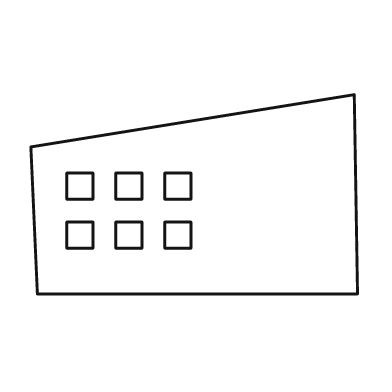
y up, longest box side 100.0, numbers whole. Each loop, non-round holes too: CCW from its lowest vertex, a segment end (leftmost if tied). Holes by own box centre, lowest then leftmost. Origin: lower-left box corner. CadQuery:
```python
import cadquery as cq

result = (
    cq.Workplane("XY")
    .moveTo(2.0, 0.0)
    .lineTo(100.0, 0.0)
    .lineTo(99.0, 61.0)
    .lineTo(0.0, 45.0)
    .close()
    .moveTo(11.0, 14.0)
    .lineTo(19.0, 14.0)
    .lineTo(19.0, 22.0)
    .lineTo(11.0, 22.0)
    .close()
    .moveTo(26.0, 14.0)
    .lineTo(34.0, 14.0)
    .lineTo(34.0, 22.0)
    .lineTo(26.0, 22.0)
    .close()
    .moveTo(41.0, 14.0)
    .lineTo(49.0, 14.0)
    .lineTo(49.0, 22.0)
    .lineTo(41.0, 22.0)
    .close()
    .moveTo(11.0, 29.0)
    .lineTo(19.0, 29.0)
    .lineTo(19.0, 37.0)
    .lineTo(11.0, 37.0)
    .close()
    .moveTo(26.0, 29.0)
    .lineTo(34.0, 29.0)
    .lineTo(34.0, 37.0)
    .lineTo(26.0, 37.0)
    .close()
    .moveTo(41.0, 29.0)
    .lineTo(49.0, 29.0)
    .lineTo(49.0, 37.0)
    .lineTo(41.0, 37.0)
    .close()
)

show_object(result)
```